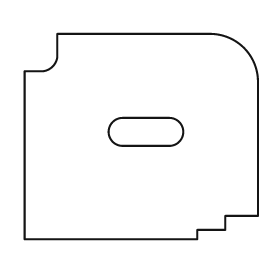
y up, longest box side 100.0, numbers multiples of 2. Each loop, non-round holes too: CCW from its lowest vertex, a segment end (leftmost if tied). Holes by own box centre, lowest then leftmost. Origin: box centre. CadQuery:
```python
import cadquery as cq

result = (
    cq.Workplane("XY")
    .moveTo(-50.0, -44.0)
    .lineTo(24.0, -44.0)
    .lineTo(24.0, -40.0)
    .lineTo(36.0, -40.0)
    .lineTo(36.0, -34.0)
    .lineTo(50.0, -34.0)
    .lineTo(50.0, 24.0)
    .threePointArc((44.0, 38.0), (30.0, 44.0))
    .lineTo(-36.0, 44.0)
    .lineTo(-36.0, 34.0)
    .threePointArc((-38.0, 30.0), (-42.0, 28.0))
    .lineTo(-50.0, 28.0)
    .close()
    .moveTo(-8.0, -4.0)
    .lineTo(12.0, -4.0)
    .threePointArc((18.0, 2.0), (12.0, 8.0))
    .lineTo(-8.0, 8.0)
    .threePointArc((-14.0, 2.0), (-8.0, -4.0))
    .close()
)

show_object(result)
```